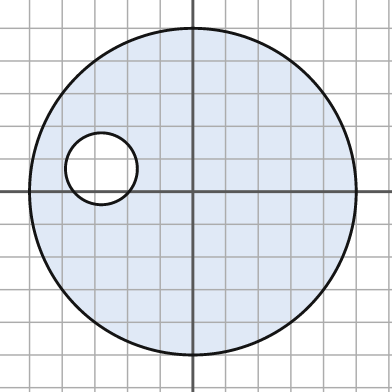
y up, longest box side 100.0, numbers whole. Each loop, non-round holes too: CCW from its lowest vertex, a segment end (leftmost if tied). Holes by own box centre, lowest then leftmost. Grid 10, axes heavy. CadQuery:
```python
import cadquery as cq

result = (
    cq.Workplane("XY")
    .moveTo(0.0, 0.0)
    .circle(50.0)
    .moveTo(-28.0, 7.0)
    .circle(11.0)
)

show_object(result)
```